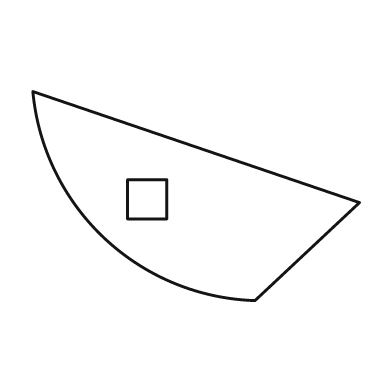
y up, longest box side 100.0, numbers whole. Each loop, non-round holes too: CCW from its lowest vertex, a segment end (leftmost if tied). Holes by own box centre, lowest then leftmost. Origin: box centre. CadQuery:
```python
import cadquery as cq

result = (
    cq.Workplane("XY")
    .moveTo(18.0, -32.0)
    .lineTo(50.0, -2.0)
    .lineTo(-50.0, 32.0)
    .threePointArc((-28.0, -13.0), (18.0, -32.0))
    .close()
    .moveTo(-21.0, -7.0)
    .lineTo(-9.0, -7.0)
    .lineTo(-9.0, 5.0)
    .lineTo(-21.0, 5.0)
    .close()
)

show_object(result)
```